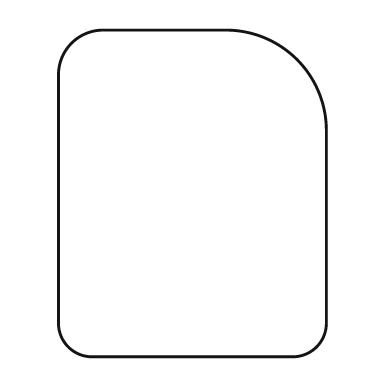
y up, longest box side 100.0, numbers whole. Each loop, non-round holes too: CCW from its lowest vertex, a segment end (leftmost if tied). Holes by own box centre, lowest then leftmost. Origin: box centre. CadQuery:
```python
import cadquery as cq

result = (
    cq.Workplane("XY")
    .moveTo(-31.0, -50.0)
    .lineTo(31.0, -50.0)
    .threePointArc((38.0, -47.0), (41.0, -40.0))
    .lineTo(41.0, 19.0)
    .threePointArc((32.0, 41.0), (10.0, 50.0))
    .lineTo(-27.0, 50.0)
    .threePointArc((-37.0, 46.0), (-41.0, 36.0))
    .lineTo(-41.0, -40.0)
    .threePointArc((-38.0, -47.0), (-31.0, -50.0))
    .close()
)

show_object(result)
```